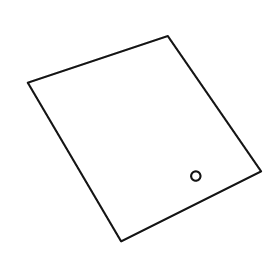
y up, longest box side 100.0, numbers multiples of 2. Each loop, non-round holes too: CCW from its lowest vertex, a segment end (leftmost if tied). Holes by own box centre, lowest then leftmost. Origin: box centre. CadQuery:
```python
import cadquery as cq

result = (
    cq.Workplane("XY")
    .moveTo(-10.0, -44.0)
    .lineTo(50.0, -14.0)
    .lineTo(10.0, 44.0)
    .lineTo(-50.0, 24.0)
    .close()
    .moveTo(22.0, -16.0)
    .circle(2.0)
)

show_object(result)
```